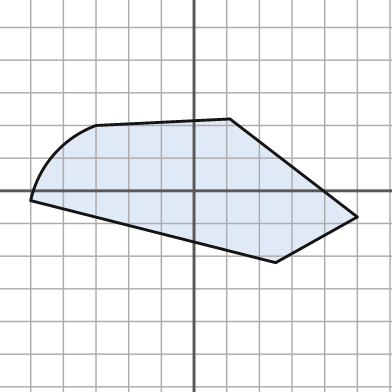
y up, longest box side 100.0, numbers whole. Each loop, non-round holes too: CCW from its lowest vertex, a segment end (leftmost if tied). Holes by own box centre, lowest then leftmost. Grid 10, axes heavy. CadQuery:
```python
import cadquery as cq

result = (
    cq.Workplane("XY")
    .moveTo(25.0, -22.0)
    .lineTo(50.0, -8.0)
    .lineTo(11.0, 22.0)
    .lineTo(-30.0, 20.0)
    .threePointArc((-43.0, 11.0), (-50.0, -3.0))
    .close()
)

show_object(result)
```